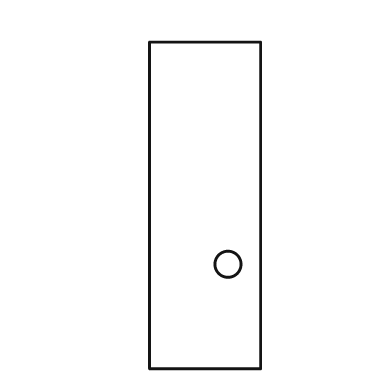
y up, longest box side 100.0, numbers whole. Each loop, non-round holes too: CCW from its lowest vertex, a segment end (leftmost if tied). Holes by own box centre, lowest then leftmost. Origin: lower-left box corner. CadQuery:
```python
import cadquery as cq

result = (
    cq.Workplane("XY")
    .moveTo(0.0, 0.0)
    .lineTo(34.0, 0.0)
    .lineTo(34.0, 100.0)
    .lineTo(0.0, 100.0)
    .close()
    .moveTo(24.0, 32.0)
    .circle(4.0)
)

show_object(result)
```